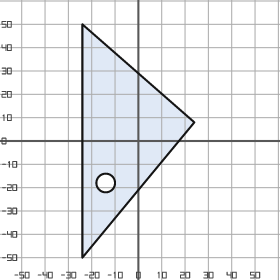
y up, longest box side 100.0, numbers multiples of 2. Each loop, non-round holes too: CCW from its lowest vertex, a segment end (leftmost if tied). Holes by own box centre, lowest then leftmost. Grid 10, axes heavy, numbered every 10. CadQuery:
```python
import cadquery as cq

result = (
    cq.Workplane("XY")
    .moveTo(-24.0, -50.0)
    .lineTo(24.0, 8.0)
    .lineTo(-24.0, 50.0)
    .close()
    .moveTo(-14.0, -18.0)
    .circle(4.0)
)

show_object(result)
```